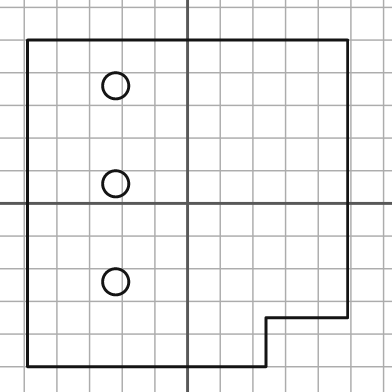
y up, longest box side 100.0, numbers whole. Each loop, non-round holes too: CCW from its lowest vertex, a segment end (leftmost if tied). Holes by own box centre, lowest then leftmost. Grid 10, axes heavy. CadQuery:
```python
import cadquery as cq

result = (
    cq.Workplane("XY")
    .moveTo(-49.0, -50.0)
    .lineTo(24.0, -50.0)
    .lineTo(24.0, -35.0)
    .lineTo(49.0, -35.0)
    .lineTo(49.0, 50.0)
    .lineTo(-49.0, 50.0)
    .close()
    .moveTo(-22.0, -24.0)
    .circle(4.0)
    .moveTo(-22.0, 6.0)
    .circle(4.0)
    .moveTo(-22.0, 36.0)
    .circle(4.0)
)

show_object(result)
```